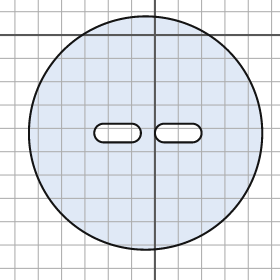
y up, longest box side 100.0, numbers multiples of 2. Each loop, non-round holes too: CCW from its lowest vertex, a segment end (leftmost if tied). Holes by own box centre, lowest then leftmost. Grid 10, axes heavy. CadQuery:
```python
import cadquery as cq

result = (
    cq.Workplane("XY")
    .moveTo(-4.0, -42.0)
    .circle(50.0)
    .moveTo(-22.0, -46.0)
    .lineTo(-10.0, -46.0)
    .threePointArc((-6.0, -42.0), (-10.0, -38.0))
    .lineTo(-22.0, -38.0)
    .threePointArc((-26.0, -42.0), (-22.0, -46.0))
    .close()
    .moveTo(4.0, -46.0)
    .lineTo(16.0, -46.0)
    .threePointArc((20.0, -42.0), (16.0, -38.0))
    .lineTo(4.0, -38.0)
    .threePointArc((0.0, -42.0), (4.0, -46.0))
    .close()
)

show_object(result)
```